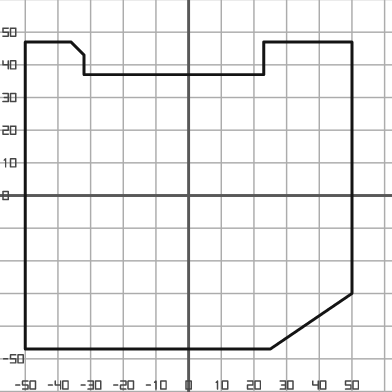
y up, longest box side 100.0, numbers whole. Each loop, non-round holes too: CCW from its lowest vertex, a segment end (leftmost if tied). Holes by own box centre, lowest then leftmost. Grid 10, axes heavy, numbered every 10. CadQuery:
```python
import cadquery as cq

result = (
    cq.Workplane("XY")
    .moveTo(-50.0, -47.0)
    .lineTo(25.0, -47.0)
    .lineTo(50.0, -30.0)
    .lineTo(50.0, 47.0)
    .lineTo(23.0, 47.0)
    .lineTo(23.0, 37.0)
    .lineTo(-32.0, 37.0)
    .lineTo(-32.0, 43.0)
    .lineTo(-36.0, 47.0)
    .lineTo(-50.0, 47.0)
    .close()
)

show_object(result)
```